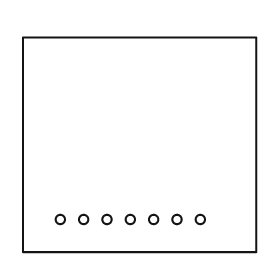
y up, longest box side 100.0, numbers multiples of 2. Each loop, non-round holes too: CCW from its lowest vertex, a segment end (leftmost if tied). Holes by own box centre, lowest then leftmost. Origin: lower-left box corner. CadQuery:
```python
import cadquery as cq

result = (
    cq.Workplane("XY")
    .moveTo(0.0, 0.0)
    .lineTo(100.0, 0.0)
    .lineTo(100.0, 92.0)
    .lineTo(0.0, 92.0)
    .close()
    .moveTo(16.0, 14.0)
    .circle(2.0)
    .moveTo(26.0, 14.0)
    .circle(2.0)
    .moveTo(36.0, 14.0)
    .circle(2.0)
    .moveTo(46.0, 14.0)
    .circle(2.0)
    .moveTo(56.0, 14.0)
    .circle(2.0)
    .moveTo(66.0, 14.0)
    .circle(2.0)
    .moveTo(76.0, 14.0)
    .circle(2.0)
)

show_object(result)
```